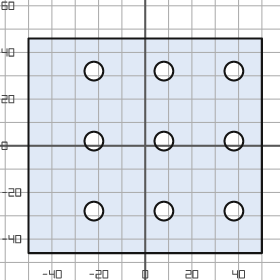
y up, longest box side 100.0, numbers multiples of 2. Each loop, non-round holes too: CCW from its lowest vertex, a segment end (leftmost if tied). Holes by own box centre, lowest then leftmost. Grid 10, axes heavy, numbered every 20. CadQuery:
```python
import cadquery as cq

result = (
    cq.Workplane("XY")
    .moveTo(-50.0, -46.0)
    .lineTo(50.0, -46.0)
    .lineTo(50.0, 46.0)
    .lineTo(-50.0, 46.0)
    .close()
    .moveTo(-22.0, -28.0)
    .circle(4.0)
    .moveTo(8.0, -28.0)
    .circle(4.0)
    .moveTo(38.0, -28.0)
    .circle(4.0)
    .moveTo(-22.0, 2.0)
    .circle(4.0)
    .moveTo(8.0, 2.0)
    .circle(4.0)
    .moveTo(38.0, 2.0)
    .circle(4.0)
    .moveTo(-22.0, 32.0)
    .circle(4.0)
    .moveTo(8.0, 32.0)
    .circle(4.0)
    .moveTo(38.0, 32.0)
    .circle(4.0)
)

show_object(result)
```